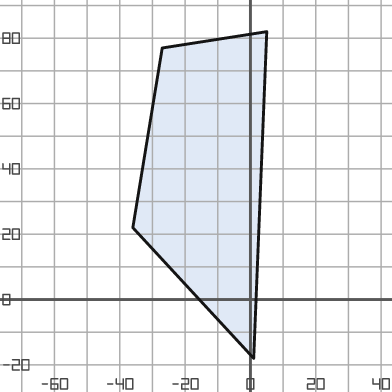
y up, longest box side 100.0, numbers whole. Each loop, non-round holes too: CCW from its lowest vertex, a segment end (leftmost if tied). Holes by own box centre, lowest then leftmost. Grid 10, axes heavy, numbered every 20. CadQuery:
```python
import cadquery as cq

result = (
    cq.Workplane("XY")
    .moveTo(1.0, -18.0)
    .lineTo(5.0, 82.0)
    .lineTo(-27.0, 77.0)
    .lineTo(-36.0, 22.0)
    .close()
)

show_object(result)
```